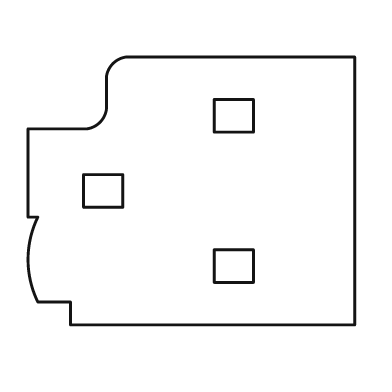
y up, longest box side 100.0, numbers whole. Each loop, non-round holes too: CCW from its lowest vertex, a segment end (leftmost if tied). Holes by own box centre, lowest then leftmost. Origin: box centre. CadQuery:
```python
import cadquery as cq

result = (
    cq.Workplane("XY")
    .moveTo(-37.0, -41.0)
    .lineTo(50.0, -41.0)
    .lineTo(50.0, 41.0)
    .lineTo(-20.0, 41.0)
    .threePointArc((-24.0, 39.0), (-26.0, 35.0))
    .lineTo(-26.0, 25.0)
    .threePointArc((-28.0, 21.0), (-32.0, 19.0))
    .lineTo(-50.0, 19.0)
    .lineTo(-50.0, -8.0)
    .lineTo(-47.0, -8.0)
    .threePointArc((-50.0, -21.0), (-47.0, -34.0))
    .lineTo(-37.0, -34.0)
    .close()
    .moveTo(7.0, -28.0)
    .lineTo(19.0, -28.0)
    .lineTo(19.0, -18.0)
    .lineTo(7.0, -18.0)
    .close()
    .moveTo(-33.0, -5.0)
    .lineTo(-21.0, -5.0)
    .lineTo(-21.0, 5.0)
    .lineTo(-33.0, 5.0)
    .close()
    .moveTo(7.0, 18.0)
    .lineTo(19.0, 18.0)
    .lineTo(19.0, 28.0)
    .lineTo(7.0, 28.0)
    .close()
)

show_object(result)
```